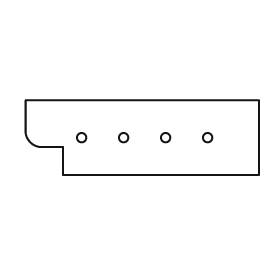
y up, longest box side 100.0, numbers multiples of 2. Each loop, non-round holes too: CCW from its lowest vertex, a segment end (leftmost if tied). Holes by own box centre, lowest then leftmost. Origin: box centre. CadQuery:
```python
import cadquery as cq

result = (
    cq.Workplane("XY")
    .moveTo(-34.0, -16.0)
    .lineTo(50.0, -16.0)
    .lineTo(50.0, 16.0)
    .lineTo(-50.0, 16.0)
    .lineTo(-50.0, 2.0)
    .threePointArc((-48.0, -2.0), (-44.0, -4.0))
    .lineTo(-34.0, -4.0)
    .close()
    .moveTo(-26.0, 0.0)
    .circle(2.0)
    .moveTo(-8.0, 0.0)
    .circle(2.0)
    .moveTo(10.0, 0.0)
    .circle(2.0)
    .moveTo(28.0, 0.0)
    .circle(2.0)
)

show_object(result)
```